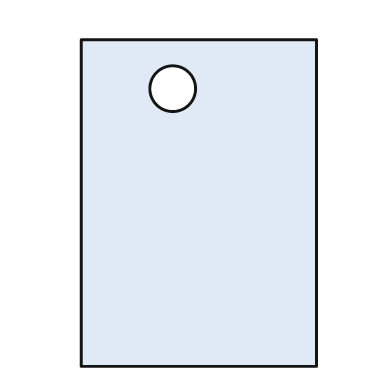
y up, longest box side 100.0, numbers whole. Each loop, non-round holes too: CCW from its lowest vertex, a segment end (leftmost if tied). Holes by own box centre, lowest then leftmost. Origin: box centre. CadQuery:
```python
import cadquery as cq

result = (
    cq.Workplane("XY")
    .moveTo(-36.0, -50.0)
    .lineTo(36.0, -50.0)
    .lineTo(36.0, 50.0)
    .lineTo(-36.0, 50.0)
    .close()
    .moveTo(-8.0, 35.0)
    .circle(7.0)
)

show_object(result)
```